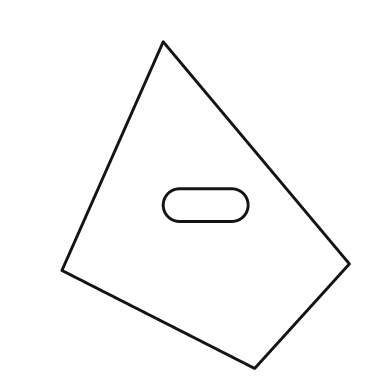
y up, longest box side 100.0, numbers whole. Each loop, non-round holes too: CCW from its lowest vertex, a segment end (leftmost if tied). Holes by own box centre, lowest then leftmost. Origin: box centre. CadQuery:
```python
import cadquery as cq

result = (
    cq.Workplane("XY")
    .moveTo(15.0, -50.0)
    .lineTo(44.0, -18.0)
    .lineTo(-13.0, 50.0)
    .lineTo(-44.0, -20.0)
    .close()
    .moveTo(-8.0, -5.0)
    .lineTo(8.0, -5.0)
    .threePointArc((13.0, 0.0), (8.0, 5.0))
    .lineTo(-8.0, 5.0)
    .threePointArc((-13.0, 0.0), (-8.0, -5.0))
    .close()
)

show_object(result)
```